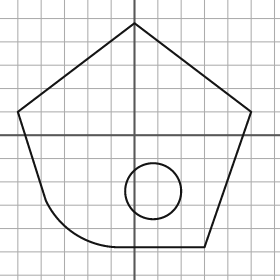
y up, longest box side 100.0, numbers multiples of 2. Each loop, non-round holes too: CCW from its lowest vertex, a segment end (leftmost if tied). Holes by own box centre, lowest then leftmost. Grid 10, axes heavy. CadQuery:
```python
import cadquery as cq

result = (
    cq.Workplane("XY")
    .moveTo(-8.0, -48.0)
    .lineTo(30.0, -48.0)
    .lineTo(50.0, 10.0)
    .lineTo(0.0, 48.0)
    .lineTo(-50.0, 10.0)
    .lineTo(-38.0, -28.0)
    .threePointArc((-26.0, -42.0), (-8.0, -48.0))
    .close()
    .moveTo(8.0, -24.0)
    .circle(12.0)
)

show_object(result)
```